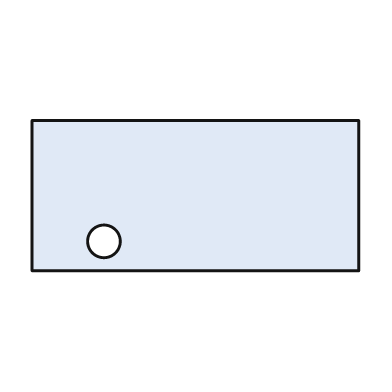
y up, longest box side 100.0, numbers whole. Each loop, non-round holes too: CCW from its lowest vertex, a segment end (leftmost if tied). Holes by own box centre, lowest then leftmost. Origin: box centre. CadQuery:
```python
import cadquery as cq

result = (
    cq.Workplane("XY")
    .moveTo(-50.0, -23.0)
    .lineTo(50.0, -23.0)
    .lineTo(50.0, 23.0)
    .lineTo(-50.0, 23.0)
    .close()
    .moveTo(-28.0, -14.0)
    .circle(5.0)
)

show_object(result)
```